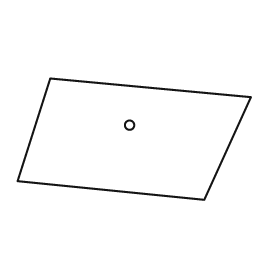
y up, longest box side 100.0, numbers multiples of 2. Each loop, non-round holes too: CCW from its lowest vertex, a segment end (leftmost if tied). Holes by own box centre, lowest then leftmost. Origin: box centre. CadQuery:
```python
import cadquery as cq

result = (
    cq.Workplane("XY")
    .moveTo(30.0, -26.0)
    .lineTo(50.0, 18.0)
    .lineTo(-36.0, 26.0)
    .lineTo(-50.0, -18.0)
    .close()
    .moveTo(-2.0, 6.0)
    .circle(2.0)
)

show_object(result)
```